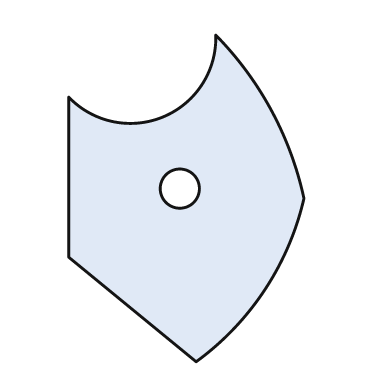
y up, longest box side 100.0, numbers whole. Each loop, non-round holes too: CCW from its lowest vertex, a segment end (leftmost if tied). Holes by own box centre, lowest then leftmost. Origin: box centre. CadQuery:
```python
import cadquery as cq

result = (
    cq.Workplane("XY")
    .moveTo(3.0, -50.0)
    .threePointArc((24.0, -28.0), (36.0, 0.0))
    .threePointArc((26.0, 27.0), (9.0, 50.0))
    .threePointArc((-7.0, 25.0), (-36.0, 31.0))
    .lineTo(-36.0, -18.0)
    .close()
    .moveTo(-2.0, 3.0)
    .circle(6.0)
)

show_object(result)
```